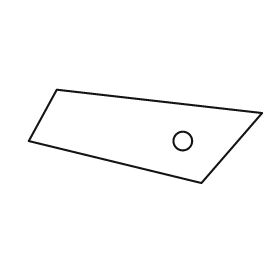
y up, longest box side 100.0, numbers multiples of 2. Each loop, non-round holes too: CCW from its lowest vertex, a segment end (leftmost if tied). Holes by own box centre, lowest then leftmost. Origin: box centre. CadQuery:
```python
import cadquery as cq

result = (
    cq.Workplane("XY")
    .moveTo(24.0, -20.0)
    .lineTo(50.0, 10.0)
    .lineTo(-38.0, 20.0)
    .lineTo(-50.0, -2.0)
    .close()
    .moveTo(16.0, -2.0)
    .circle(4.0)
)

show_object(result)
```